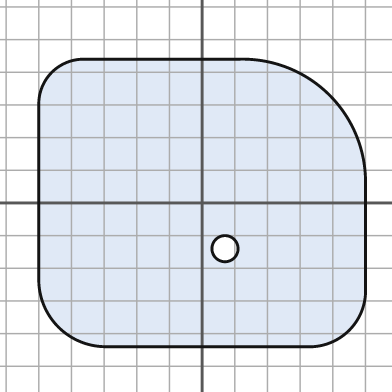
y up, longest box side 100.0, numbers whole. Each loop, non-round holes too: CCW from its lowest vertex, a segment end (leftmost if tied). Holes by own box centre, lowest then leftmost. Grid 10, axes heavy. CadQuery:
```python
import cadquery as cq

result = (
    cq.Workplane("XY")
    .moveTo(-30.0, -44.0)
    .lineTo(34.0, -44.0)
    .threePointArc((45.0, -39.0), (50.0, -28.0))
    .lineTo(50.0, 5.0)
    .threePointArc((39.0, 33.0), (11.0, 44.0))
    .lineTo(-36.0, 44.0)
    .threePointArc((-46.0, 40.0), (-50.0, 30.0))
    .lineTo(-50.0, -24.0)
    .threePointArc((-44.0, -38.0), (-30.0, -44.0))
    .close()
    .moveTo(7.0, -14.0)
    .circle(4.0)
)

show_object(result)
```